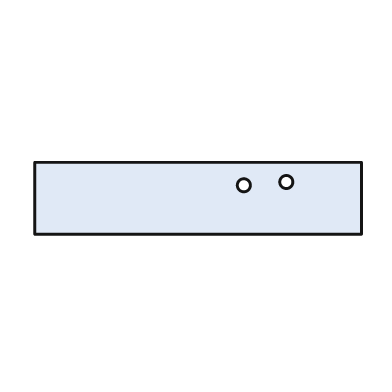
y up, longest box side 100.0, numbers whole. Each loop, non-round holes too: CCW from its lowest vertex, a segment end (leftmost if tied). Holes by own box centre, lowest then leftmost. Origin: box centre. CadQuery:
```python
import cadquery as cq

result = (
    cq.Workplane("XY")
    .moveTo(-50.0, -11.0)
    .lineTo(50.0, -11.0)
    .lineTo(50.0, 11.0)
    .lineTo(-50.0, 11.0)
    .close()
    .moveTo(14.0, 4.0)
    .circle(2.0)
    .moveTo(27.0, 5.0)
    .circle(2.0)
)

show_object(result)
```